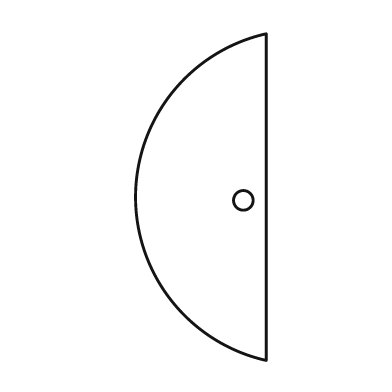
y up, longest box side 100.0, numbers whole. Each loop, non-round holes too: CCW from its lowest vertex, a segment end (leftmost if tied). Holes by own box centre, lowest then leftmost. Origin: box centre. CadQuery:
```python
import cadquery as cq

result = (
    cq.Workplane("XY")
    .moveTo(20.0, -50.0)
    .lineTo(20.0, 50.0)
    .threePointArc((-20.0, 0.0), (20.0, -50.0))
    .close()
    .moveTo(13.0, -1.0)
    .circle(3.0)
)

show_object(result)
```